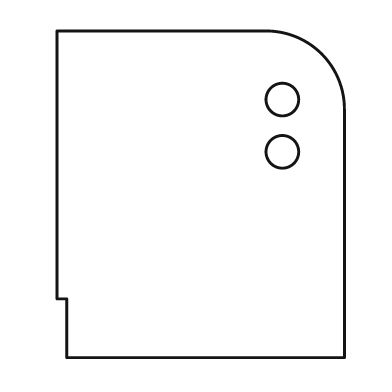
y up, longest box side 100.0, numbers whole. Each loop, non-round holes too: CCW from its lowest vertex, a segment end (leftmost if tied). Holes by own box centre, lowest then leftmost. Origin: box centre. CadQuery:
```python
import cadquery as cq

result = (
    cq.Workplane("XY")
    .moveTo(-41.0, -50.0)
    .lineTo(44.0, -50.0)
    .lineTo(44.0, 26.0)
    .threePointArc((37.0, 43.0), (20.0, 50.0))
    .lineTo(-44.0, 50.0)
    .lineTo(-44.0, -32.0)
    .lineTo(-41.0, -32.0)
    .close()
    .moveTo(25.0, 13.0)
    .circle(5.0)
    .moveTo(25.0, 29.0)
    .circle(5.0)
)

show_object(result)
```